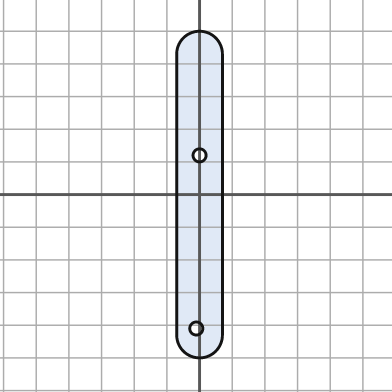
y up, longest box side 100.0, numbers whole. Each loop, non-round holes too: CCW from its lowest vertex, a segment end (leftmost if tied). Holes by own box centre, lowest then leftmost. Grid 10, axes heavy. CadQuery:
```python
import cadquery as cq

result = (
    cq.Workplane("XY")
    .moveTo(-7.0, -43.0)
    .threePointArc((0.0, -50.0), (7.0, -43.0))
    .lineTo(7.0, 43.0)
    .threePointArc((0.0, 50.0), (-7.0, 43.0))
    .close()
    .moveTo(-1.0, -41.0)
    .circle(2.0)
    .moveTo(0.0, 12.0)
    .circle(2.0)
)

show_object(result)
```